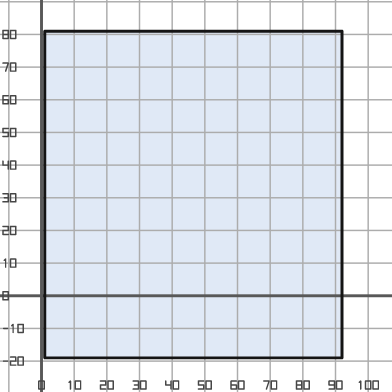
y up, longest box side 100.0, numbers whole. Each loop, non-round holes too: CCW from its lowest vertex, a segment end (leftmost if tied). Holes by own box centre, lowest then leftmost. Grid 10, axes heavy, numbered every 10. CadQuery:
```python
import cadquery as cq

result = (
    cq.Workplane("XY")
    .moveTo(1.0, -19.0)
    .lineTo(92.0, -19.0)
    .lineTo(92.0, 81.0)
    .lineTo(1.0, 81.0)
    .close()
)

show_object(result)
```